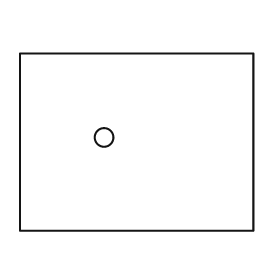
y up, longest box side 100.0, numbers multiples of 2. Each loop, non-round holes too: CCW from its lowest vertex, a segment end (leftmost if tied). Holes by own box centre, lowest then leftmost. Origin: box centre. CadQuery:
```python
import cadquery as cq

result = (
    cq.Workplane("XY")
    .moveTo(-50.0, -38.0)
    .lineTo(50.0, -38.0)
    .lineTo(50.0, 38.0)
    .lineTo(-50.0, 38.0)
    .close()
    .moveTo(-14.0, 2.0)
    .circle(4.0)
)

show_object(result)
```